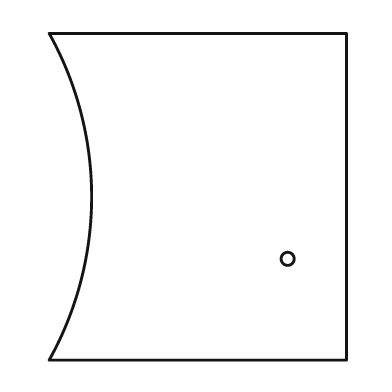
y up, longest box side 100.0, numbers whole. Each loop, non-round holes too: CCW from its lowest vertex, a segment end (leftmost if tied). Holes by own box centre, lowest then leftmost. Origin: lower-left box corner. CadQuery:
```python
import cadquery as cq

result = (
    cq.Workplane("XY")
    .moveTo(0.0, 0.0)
    .lineTo(91.0, 0.0)
    .lineTo(91.0, 100.0)
    .lineTo(0.0, 100.0)
    .threePointArc((13.0, 50.0), (0.0, 0.0))
    .close()
    .moveTo(73.0, 31.0)
    .circle(2.0)
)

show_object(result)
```